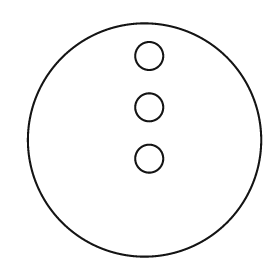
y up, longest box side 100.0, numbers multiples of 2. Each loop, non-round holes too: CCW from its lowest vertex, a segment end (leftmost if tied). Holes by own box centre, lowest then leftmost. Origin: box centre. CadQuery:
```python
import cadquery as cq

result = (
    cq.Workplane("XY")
    .moveTo(0.0, 0.0)
    .circle(50.0)
    .moveTo(2.0, -8.0)
    .circle(6.0)
    .moveTo(2.0, 14.0)
    .circle(6.0)
    .moveTo(2.0, 36.0)
    .circle(6.0)
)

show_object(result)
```